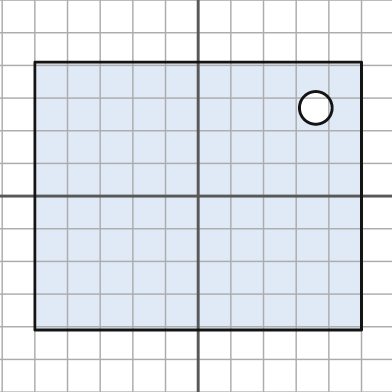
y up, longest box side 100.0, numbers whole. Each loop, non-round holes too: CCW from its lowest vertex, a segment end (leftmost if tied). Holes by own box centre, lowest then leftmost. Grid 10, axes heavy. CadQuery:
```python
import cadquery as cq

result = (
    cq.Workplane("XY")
    .moveTo(-50.0, -41.0)
    .lineTo(50.0, -41.0)
    .lineTo(50.0, 41.0)
    .lineTo(-50.0, 41.0)
    .close()
    .moveTo(36.0, 27.0)
    .circle(5.0)
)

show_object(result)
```